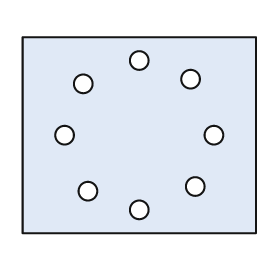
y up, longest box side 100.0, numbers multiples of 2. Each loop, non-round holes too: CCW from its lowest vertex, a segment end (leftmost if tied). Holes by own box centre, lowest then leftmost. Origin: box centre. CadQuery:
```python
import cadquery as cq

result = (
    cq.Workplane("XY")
    .moveTo(-50.0, -42.0)
    .lineTo(50.0, -42.0)
    .lineTo(50.0, 42.0)
    .lineTo(-50.0, 42.0)
    .close()
    .moveTo(0.0, -32.0)
    .circle(4.0)
    .moveTo(-22.0, -24.0)
    .circle(4.0)
    .moveTo(24.0, -22.0)
    .circle(4.0)
    .moveTo(-32.0, 0.0)
    .circle(4.0)
    .moveTo(32.0, 0.0)
    .circle(4.0)
    .moveTo(-24.0, 22.0)
    .circle(4.0)
    .moveTo(22.0, 24.0)
    .circle(4.0)
    .moveTo(0.0, 32.0)
    .circle(4.0)
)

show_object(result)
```